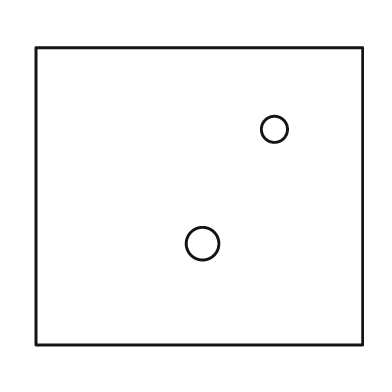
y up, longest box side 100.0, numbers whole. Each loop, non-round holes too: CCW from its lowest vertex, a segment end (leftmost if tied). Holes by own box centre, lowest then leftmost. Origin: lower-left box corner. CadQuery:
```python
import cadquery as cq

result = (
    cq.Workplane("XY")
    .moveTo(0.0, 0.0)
    .lineTo(100.0, 0.0)
    .lineTo(100.0, 91.0)
    .lineTo(0.0, 91.0)
    .close()
    .moveTo(51.0, 31.0)
    .circle(5.0)
    .moveTo(73.0, 66.0)
    .circle(4.0)
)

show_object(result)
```